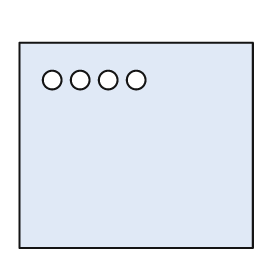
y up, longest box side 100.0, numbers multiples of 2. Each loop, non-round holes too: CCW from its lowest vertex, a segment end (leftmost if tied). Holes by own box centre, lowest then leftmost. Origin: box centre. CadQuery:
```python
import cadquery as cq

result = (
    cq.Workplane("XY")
    .moveTo(-50.0, -44.0)
    .lineTo(50.0, -44.0)
    .lineTo(50.0, 44.0)
    .lineTo(-50.0, 44.0)
    .close()
    .moveTo(-36.0, 28.0)
    .circle(4.0)
    .moveTo(-24.0, 28.0)
    .circle(4.0)
    .moveTo(-12.0, 28.0)
    .circle(4.0)
    .moveTo(0.0, 28.0)
    .circle(4.0)
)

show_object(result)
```